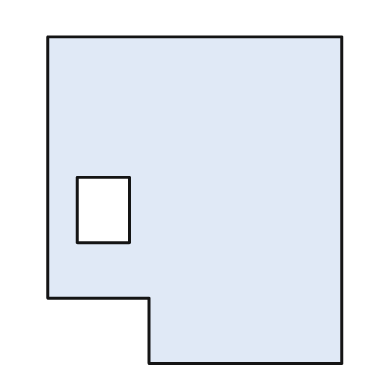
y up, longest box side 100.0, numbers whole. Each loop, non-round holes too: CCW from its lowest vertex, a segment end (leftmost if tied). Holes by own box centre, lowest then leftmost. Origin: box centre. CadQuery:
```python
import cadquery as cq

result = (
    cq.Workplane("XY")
    .moveTo(-14.0, -50.0)
    .lineTo(45.0, -50.0)
    .lineTo(45.0, 50.0)
    .lineTo(-45.0, 50.0)
    .lineTo(-45.0, -30.0)
    .lineTo(-14.0, -30.0)
    .close()
    .moveTo(-36.0, -13.0)
    .lineTo(-20.0, -13.0)
    .lineTo(-20.0, 7.0)
    .lineTo(-36.0, 7.0)
    .close()
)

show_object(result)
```